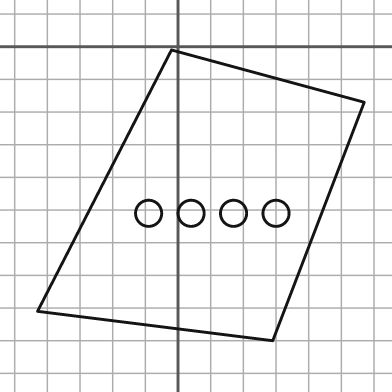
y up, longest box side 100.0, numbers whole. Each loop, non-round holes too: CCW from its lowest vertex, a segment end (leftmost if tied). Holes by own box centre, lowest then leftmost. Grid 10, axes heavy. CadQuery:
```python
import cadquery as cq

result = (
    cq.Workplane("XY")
    .moveTo(29.0, -90.0)
    .lineTo(57.0, -17.0)
    .lineTo(-2.0, -1.0)
    .lineTo(-43.0, -81.0)
    .close()
    .moveTo(-9.0, -51.0)
    .circle(4.0)
    .moveTo(4.0, -51.0)
    .circle(4.0)
    .moveTo(17.0, -51.0)
    .circle(4.0)
    .moveTo(30.0, -51.0)
    .circle(4.0)
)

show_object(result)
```